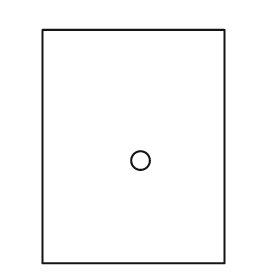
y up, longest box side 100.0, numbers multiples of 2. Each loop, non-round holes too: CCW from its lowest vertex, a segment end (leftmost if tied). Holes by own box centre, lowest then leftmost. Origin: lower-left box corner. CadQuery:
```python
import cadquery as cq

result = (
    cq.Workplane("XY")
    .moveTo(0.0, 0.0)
    .lineTo(78.0, 0.0)
    .lineTo(78.0, 100.0)
    .lineTo(0.0, 100.0)
    .close()
    .moveTo(42.0, 44.0)
    .circle(4.0)
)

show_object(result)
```